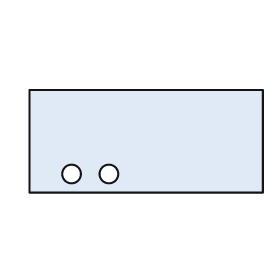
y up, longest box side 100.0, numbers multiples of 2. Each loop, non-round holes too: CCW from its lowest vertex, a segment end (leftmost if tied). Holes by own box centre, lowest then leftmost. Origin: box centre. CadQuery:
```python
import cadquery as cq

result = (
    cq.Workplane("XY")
    .moveTo(-50.0, -22.0)
    .lineTo(50.0, -22.0)
    .lineTo(50.0, 22.0)
    .lineTo(-50.0, 22.0)
    .close()
    .moveTo(-32.0, -14.0)
    .circle(4.0)
    .moveTo(-16.0, -14.0)
    .circle(4.0)
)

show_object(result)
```